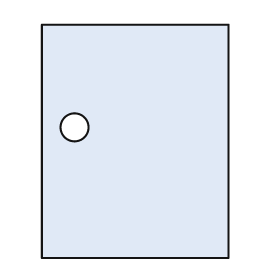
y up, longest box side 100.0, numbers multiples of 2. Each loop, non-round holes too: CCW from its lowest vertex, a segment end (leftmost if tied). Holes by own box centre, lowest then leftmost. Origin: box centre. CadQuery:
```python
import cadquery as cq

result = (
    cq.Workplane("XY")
    .moveTo(-40.0, -50.0)
    .lineTo(40.0, -50.0)
    .lineTo(40.0, 50.0)
    .lineTo(-40.0, 50.0)
    .close()
    .moveTo(-26.0, 6.0)
    .circle(6.0)
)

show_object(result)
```